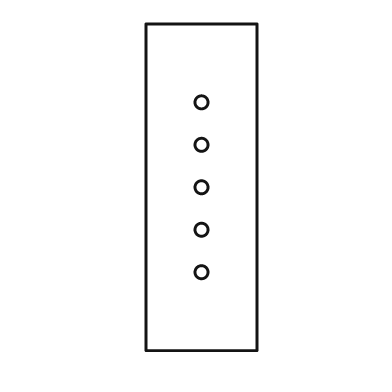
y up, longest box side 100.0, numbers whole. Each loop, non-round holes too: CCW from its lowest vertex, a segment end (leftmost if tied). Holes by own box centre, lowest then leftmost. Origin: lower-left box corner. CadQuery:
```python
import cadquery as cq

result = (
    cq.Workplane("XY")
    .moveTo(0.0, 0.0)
    .lineTo(34.0, 0.0)
    .lineTo(34.0, 100.0)
    .lineTo(0.0, 100.0)
    .close()
    .moveTo(17.0, 24.0)
    .circle(2.0)
    .moveTo(17.0, 37.0)
    .circle(2.0)
    .moveTo(17.0, 50.0)
    .circle(2.0)
    .moveTo(17.0, 63.0)
    .circle(2.0)
    .moveTo(17.0, 76.0)
    .circle(2.0)
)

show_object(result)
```